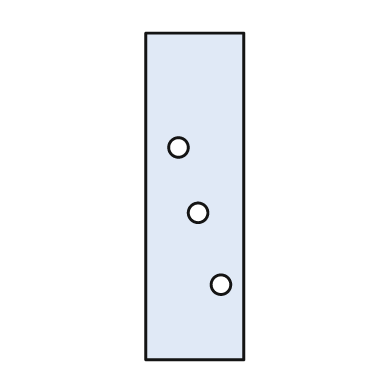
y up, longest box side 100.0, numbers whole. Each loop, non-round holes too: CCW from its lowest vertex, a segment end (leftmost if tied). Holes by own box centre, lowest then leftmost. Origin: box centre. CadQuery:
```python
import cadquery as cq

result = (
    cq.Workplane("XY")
    .moveTo(-15.0, -50.0)
    .lineTo(15.0, -50.0)
    .lineTo(15.0, 50.0)
    .lineTo(-15.0, 50.0)
    .close()
    .moveTo(8.0, -27.0)
    .circle(3.0)
    .moveTo(1.0, -5.0)
    .circle(3.0)
    .moveTo(-5.0, 15.0)
    .circle(3.0)
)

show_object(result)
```